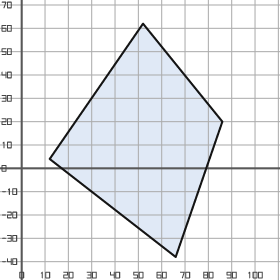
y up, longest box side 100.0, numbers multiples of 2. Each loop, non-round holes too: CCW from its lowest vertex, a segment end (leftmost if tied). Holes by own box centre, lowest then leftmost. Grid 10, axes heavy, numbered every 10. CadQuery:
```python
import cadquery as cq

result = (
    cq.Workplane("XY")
    .moveTo(66.0, -38.0)
    .lineTo(86.0, 20.0)
    .lineTo(52.0, 62.0)
    .lineTo(12.0, 4.0)
    .close()
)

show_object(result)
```